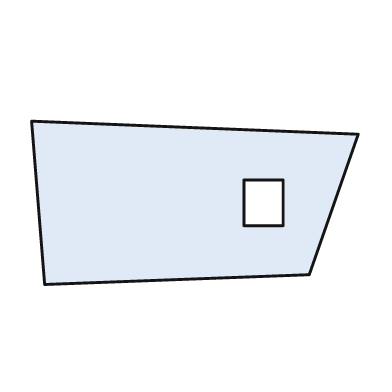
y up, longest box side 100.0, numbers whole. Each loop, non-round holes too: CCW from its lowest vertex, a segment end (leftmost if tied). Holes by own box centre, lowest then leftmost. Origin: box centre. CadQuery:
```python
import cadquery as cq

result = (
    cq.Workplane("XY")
    .moveTo(-46.0, -25.0)
    .lineTo(35.0, -22.0)
    .lineTo(50.0, 21.0)
    .lineTo(-50.0, 25.0)
    .close()
    .moveTo(15.0, -7.0)
    .lineTo(27.0, -7.0)
    .lineTo(27.0, 7.0)
    .lineTo(15.0, 7.0)
    .close()
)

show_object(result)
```